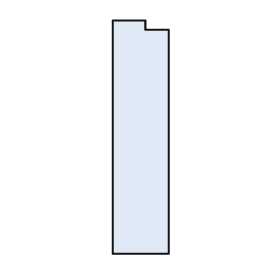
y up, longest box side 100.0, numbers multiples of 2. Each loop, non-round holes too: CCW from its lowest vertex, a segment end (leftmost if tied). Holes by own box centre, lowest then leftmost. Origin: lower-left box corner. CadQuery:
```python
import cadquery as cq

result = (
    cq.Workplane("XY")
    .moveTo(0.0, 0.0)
    .lineTo(24.0, 0.0)
    .lineTo(24.0, 96.0)
    .lineTo(14.0, 96.0)
    .lineTo(14.0, 100.0)
    .lineTo(0.0, 100.0)
    .close()
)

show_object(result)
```